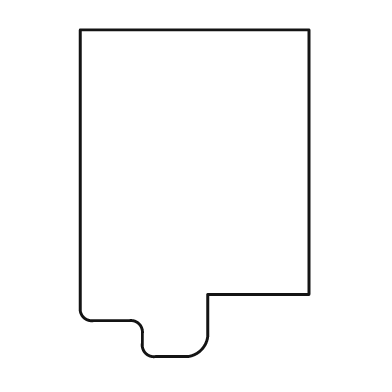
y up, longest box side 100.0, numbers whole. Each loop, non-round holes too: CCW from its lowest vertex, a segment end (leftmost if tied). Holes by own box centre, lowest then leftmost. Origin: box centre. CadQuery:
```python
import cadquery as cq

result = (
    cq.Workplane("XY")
    .moveTo(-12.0, -50.0)
    .lineTo(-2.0, -50.0)
    .threePointArc((2.0, -48.0), (4.0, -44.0))
    .lineTo(4.0, -31.0)
    .lineTo(35.0, -31.0)
    .lineTo(35.0, 50.0)
    .lineTo(-35.0, 50.0)
    .lineTo(-35.0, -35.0)
    .threePointArc((-34.0, -38.0), (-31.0, -39.0))
    .lineTo(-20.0, -39.0)
    .threePointArc((-17.0, -40.0), (-16.0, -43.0))
    .lineTo(-16.0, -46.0)
    .threePointArc((-15.0, -49.0), (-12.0, -50.0))
    .close()
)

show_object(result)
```